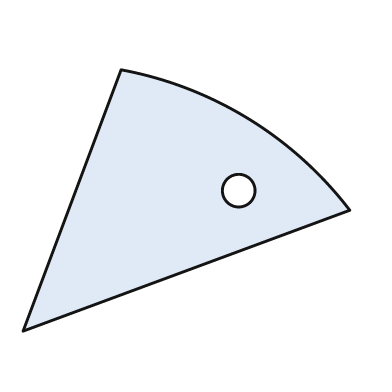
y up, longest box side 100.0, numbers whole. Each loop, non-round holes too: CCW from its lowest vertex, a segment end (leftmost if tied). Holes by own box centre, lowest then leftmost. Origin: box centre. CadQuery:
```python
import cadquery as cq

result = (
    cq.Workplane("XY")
    .moveTo(-50.0, -40.0)
    .lineTo(50.0, -3.0)
    .threePointArc((19.0, 25.0), (-20.0, 40.0))
    .close()
    .moveTo(16.0, 3.0)
    .circle(5.0)
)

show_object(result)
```